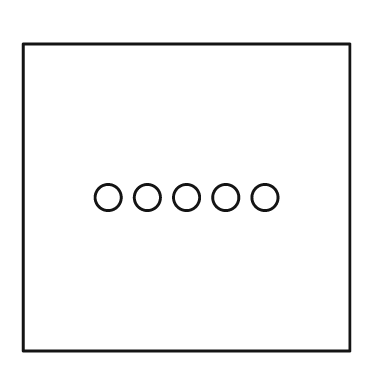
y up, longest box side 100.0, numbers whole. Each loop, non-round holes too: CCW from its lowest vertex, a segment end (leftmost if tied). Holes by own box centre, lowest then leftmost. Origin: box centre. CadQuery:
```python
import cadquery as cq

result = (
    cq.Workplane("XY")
    .moveTo(-50.0, -47.0)
    .lineTo(50.0, -47.0)
    .lineTo(50.0, 47.0)
    .lineTo(-50.0, 47.0)
    .close()
    .moveTo(-24.0, 0.0)
    .circle(4.0)
    .moveTo(-12.0, 0.0)
    .circle(4.0)
    .moveTo(0.0, 0.0)
    .circle(4.0)
    .moveTo(12.0, 0.0)
    .circle(4.0)
    .moveTo(24.0, 0.0)
    .circle(4.0)
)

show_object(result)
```